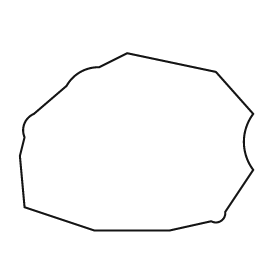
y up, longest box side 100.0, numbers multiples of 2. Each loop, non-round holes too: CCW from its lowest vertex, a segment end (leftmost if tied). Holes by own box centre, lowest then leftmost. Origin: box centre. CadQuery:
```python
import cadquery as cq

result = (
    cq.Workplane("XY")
    .moveTo(-18.0, -38.0)
    .lineTo(14.0, -38.0)
    .lineTo(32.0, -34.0)
    .threePointArc((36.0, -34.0), (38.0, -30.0))
    .lineTo(50.0, -12.0)
    .threePointArc((46.0, 0.0), (50.0, 12.0))
    .lineTo(34.0, 30.0)
    .lineTo(-4.0, 38.0)
    .lineTo(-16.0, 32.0)
    .threePointArc((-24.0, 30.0), (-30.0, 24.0))
    .lineTo(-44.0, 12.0)
    .threePointArc((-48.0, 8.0), (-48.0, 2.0))
    .lineTo(-50.0, -6.0)
    .lineTo(-48.0, -28.0)
    .close()
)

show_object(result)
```